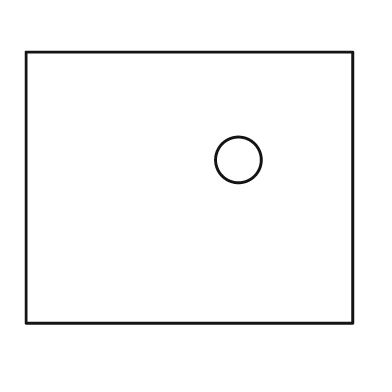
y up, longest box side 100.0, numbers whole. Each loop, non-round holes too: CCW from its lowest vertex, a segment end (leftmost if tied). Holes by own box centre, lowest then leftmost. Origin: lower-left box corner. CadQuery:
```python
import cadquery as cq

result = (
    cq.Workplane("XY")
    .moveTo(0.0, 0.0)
    .lineTo(100.0, 0.0)
    .lineTo(100.0, 83.0)
    .lineTo(0.0, 83.0)
    .close()
    .moveTo(65.0, 50.0)
    .circle(7.0)
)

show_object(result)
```